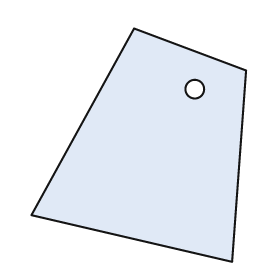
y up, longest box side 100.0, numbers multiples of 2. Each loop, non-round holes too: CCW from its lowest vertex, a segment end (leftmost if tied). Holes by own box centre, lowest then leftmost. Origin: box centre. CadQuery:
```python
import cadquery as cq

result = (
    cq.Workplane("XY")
    .moveTo(40.0, -50.0)
    .lineTo(46.0, 32.0)
    .lineTo(-2.0, 50.0)
    .lineTo(-46.0, -30.0)
    .close()
    .moveTo(24.0, 24.0)
    .circle(4.0)
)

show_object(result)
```